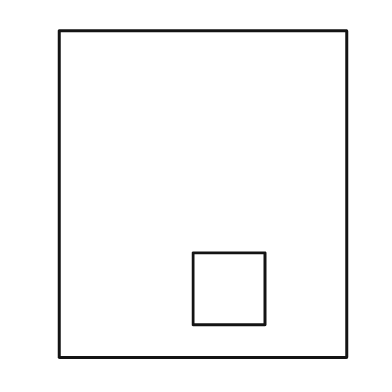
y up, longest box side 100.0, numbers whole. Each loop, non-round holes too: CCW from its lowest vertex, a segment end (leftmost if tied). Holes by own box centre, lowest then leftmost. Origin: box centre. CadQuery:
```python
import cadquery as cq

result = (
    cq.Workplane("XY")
    .moveTo(-44.0, -50.0)
    .lineTo(44.0, -50.0)
    .lineTo(44.0, 50.0)
    .lineTo(-44.0, 50.0)
    .close()
    .moveTo(-3.0, -40.0)
    .lineTo(19.0, -40.0)
    .lineTo(19.0, -18.0)
    .lineTo(-3.0, -18.0)
    .close()
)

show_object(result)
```